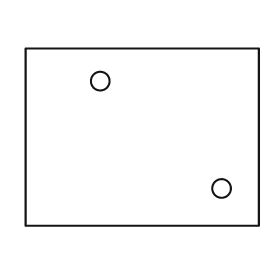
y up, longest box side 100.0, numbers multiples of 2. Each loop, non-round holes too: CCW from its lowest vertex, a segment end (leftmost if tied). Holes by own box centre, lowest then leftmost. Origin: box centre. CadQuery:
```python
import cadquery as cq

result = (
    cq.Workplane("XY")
    .moveTo(-50.0, -38.0)
    .lineTo(50.0, -38.0)
    .lineTo(50.0, 38.0)
    .lineTo(-50.0, 38.0)
    .close()
    .moveTo(34.0, -22.0)
    .circle(4.0)
    .moveTo(-18.0, 24.0)
    .circle(4.0)
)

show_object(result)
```